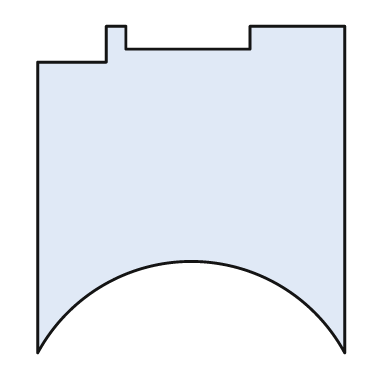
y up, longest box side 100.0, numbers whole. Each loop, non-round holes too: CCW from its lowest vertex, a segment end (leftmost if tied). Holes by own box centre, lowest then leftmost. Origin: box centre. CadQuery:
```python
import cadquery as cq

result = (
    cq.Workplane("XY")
    .moveTo(-47.0, -50.0)
    .threePointArc((0.0, -22.0), (47.0, -50.0))
    .lineTo(47.0, 50.0)
    .lineTo(18.0, 50.0)
    .lineTo(18.0, 43.0)
    .lineTo(-20.0, 43.0)
    .lineTo(-20.0, 50.0)
    .lineTo(-26.0, 50.0)
    .lineTo(-26.0, 39.0)
    .lineTo(-47.0, 39.0)
    .close()
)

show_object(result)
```